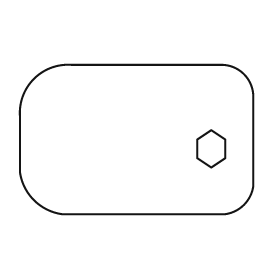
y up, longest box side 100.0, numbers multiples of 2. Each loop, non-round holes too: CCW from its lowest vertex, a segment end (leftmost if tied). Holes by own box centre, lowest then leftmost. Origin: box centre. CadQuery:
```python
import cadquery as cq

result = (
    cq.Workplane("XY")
    .moveTo(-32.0, -32.0)
    .lineTo(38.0, -32.0)
    .threePointArc((46.0, -28.0), (50.0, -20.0))
    .lineTo(50.0, 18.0)
    .threePointArc((46.0, 28.0), (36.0, 32.0))
    .lineTo(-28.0, 32.0)
    .threePointArc((-44.0, 26.0), (-50.0, 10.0))
    .lineTo(-50.0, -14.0)
    .threePointArc((-44.0, -26.0), (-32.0, -32.0))
    .close()
    .moveTo(32.0, -12.0)
    .lineTo(38.0, -8.0)
    .lineTo(38.0, 0.0)
    .lineTo(32.0, 4.0)
    .lineTo(26.0, 0.0)
    .lineTo(26.0, -8.0)
    .close()
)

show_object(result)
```